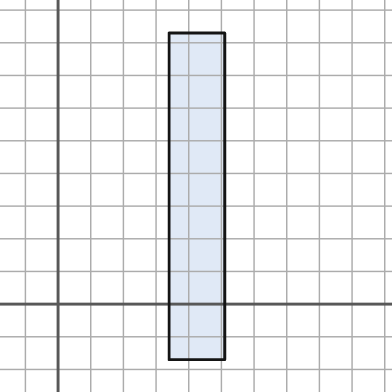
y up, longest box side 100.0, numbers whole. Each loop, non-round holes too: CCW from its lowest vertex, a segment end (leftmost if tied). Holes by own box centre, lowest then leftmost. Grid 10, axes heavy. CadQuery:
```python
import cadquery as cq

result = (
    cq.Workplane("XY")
    .moveTo(34.0, -17.0)
    .lineTo(51.0, -17.0)
    .lineTo(51.0, 83.0)
    .lineTo(34.0, 83.0)
    .close()
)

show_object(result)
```